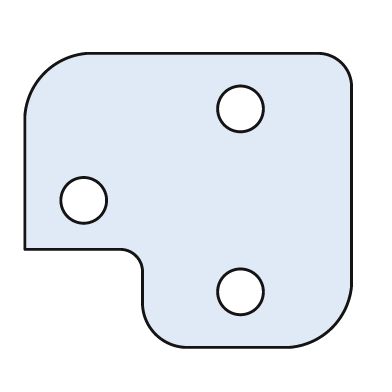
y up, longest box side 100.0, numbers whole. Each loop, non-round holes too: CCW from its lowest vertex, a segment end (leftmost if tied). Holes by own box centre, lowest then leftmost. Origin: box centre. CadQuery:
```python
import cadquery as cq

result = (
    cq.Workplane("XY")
    .moveTo(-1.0, -45.0)
    .lineTo(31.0, -45.0)
    .threePointArc((44.0, -39.0), (50.0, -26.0))
    .lineTo(50.0, 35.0)
    .threePointArc((47.0, 42.0), (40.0, 45.0))
    .lineTo(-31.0, 45.0)
    .threePointArc((-44.0, 39.0), (-50.0, 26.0))
    .lineTo(-50.0, -15.0)
    .lineTo(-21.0, -15.0)
    .threePointArc((-16.0, -17.0), (-14.0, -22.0))
    .lineTo(-14.0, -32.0)
    .threePointArc((-10.0, -41.0), (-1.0, -45.0))
    .close()
    .moveTo(16.0, -28.0)
    .circle(7.0)
    .moveTo(-32.0, 0.0)
    .circle(7.0)
    .moveTo(16.0, 28.0)
    .circle(7.0)
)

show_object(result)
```